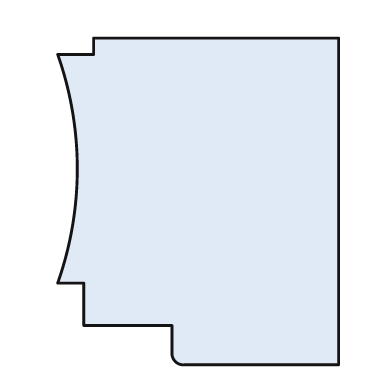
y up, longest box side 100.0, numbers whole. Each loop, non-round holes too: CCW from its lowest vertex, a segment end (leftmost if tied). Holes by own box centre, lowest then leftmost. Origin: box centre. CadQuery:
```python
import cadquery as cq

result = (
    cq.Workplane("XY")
    .moveTo(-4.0, -50.0)
    .lineTo(43.0, -50.0)
    .lineTo(43.0, 50.0)
    .lineTo(-32.0, 50.0)
    .lineTo(-32.0, 45.0)
    .lineTo(-43.0, 45.0)
    .threePointArc((-37.0, 10.0), (-43.0, -25.0))
    .lineTo(-35.0, -25.0)
    .lineTo(-35.0, -38.0)
    .lineTo(-8.0, -38.0)
    .lineTo(-8.0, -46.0)
    .threePointArc((-7.0, -49.0), (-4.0, -50.0))
    .close()
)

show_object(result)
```